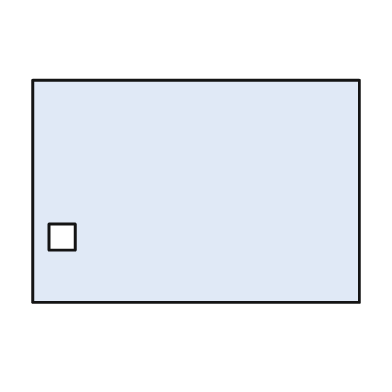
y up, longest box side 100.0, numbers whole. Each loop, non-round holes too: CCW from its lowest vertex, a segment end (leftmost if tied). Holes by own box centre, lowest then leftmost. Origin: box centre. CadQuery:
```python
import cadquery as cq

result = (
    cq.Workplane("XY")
    .moveTo(-50.0, -34.0)
    .lineTo(50.0, -34.0)
    .lineTo(50.0, 34.0)
    .lineTo(-50.0, 34.0)
    .close()
    .moveTo(-45.0, -18.0)
    .lineTo(-37.0, -18.0)
    .lineTo(-37.0, -10.0)
    .lineTo(-45.0, -10.0)
    .close()
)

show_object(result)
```